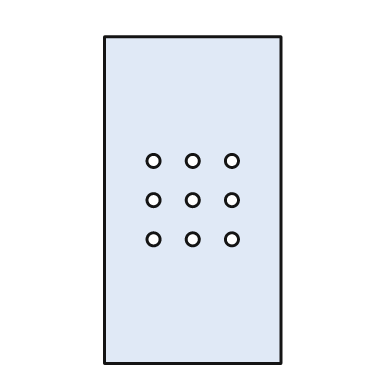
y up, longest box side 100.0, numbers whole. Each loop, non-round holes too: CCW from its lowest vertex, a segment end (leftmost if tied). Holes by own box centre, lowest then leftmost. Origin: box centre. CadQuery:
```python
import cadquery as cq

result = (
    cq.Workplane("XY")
    .moveTo(-27.0, -50.0)
    .lineTo(27.0, -50.0)
    .lineTo(27.0, 50.0)
    .lineTo(-27.0, 50.0)
    .close()
    .moveTo(-12.0, -12.0)
    .circle(2.0)
    .moveTo(0.0, -12.0)
    .circle(2.0)
    .moveTo(12.0, -12.0)
    .circle(2.0)
    .moveTo(-12.0, 0.0)
    .circle(2.0)
    .moveTo(0.0, 0.0)
    .circle(2.0)
    .moveTo(12.0, 0.0)
    .circle(2.0)
    .moveTo(-12.0, 12.0)
    .circle(2.0)
    .moveTo(0.0, 12.0)
    .circle(2.0)
    .moveTo(12.0, 12.0)
    .circle(2.0)
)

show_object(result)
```